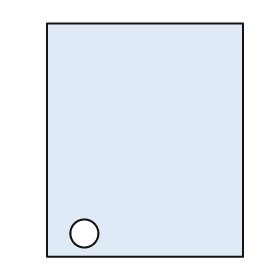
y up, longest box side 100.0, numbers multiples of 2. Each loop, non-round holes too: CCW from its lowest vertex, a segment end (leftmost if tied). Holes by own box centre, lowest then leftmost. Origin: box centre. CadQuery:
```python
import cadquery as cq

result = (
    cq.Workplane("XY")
    .moveTo(-42.0, -50.0)
    .lineTo(42.0, -50.0)
    .lineTo(42.0, 50.0)
    .lineTo(-42.0, 50.0)
    .close()
    .moveTo(-26.0, -40.0)
    .circle(6.0)
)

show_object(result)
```